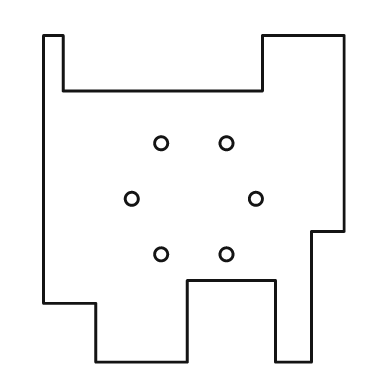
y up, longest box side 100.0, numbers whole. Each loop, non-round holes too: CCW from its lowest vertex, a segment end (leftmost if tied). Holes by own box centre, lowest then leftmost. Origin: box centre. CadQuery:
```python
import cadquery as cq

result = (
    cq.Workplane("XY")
    .moveTo(-30.0, -50.0)
    .lineTo(-2.0, -50.0)
    .lineTo(-2.0, -25.0)
    .lineTo(25.0, -25.0)
    .lineTo(25.0, -50.0)
    .lineTo(36.0, -50.0)
    .lineTo(36.0, -10.0)
    .lineTo(46.0, -10.0)
    .lineTo(46.0, 50.0)
    .lineTo(21.0, 50.0)
    .lineTo(21.0, 33.0)
    .lineTo(-40.0, 33.0)
    .lineTo(-40.0, 50.0)
    .lineTo(-46.0, 50.0)
    .lineTo(-46.0, -32.0)
    .lineTo(-30.0, -32.0)
    .close()
    .moveTo(-10.0, -17.0)
    .circle(2.0)
    .moveTo(10.0, -17.0)
    .circle(2.0)
    .moveTo(-19.0, 0.0)
    .circle(2.0)
    .moveTo(19.0, 0.0)
    .circle(2.0)
    .moveTo(-10.0, 17.0)
    .circle(2.0)
    .moveTo(10.0, 17.0)
    .circle(2.0)
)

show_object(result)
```